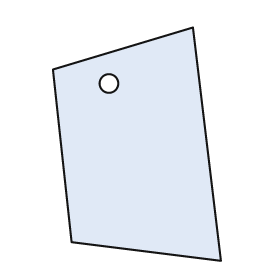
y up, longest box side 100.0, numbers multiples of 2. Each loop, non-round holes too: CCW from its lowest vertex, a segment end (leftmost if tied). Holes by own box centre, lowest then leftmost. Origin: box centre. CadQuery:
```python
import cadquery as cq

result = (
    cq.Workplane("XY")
    .moveTo(36.0, -50.0)
    .lineTo(24.0, 50.0)
    .lineTo(-36.0, 32.0)
    .lineTo(-28.0, -42.0)
    .close()
    .moveTo(-12.0, 26.0)
    .circle(4.0)
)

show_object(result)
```